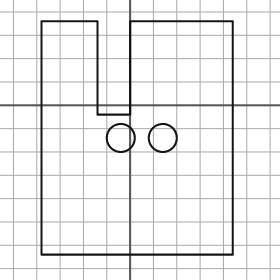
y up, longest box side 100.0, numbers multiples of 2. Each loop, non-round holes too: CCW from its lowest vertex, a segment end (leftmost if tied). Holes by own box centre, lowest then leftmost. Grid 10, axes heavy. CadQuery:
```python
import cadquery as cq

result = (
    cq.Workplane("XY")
    .moveTo(-38.0, -64.0)
    .lineTo(44.0, -64.0)
    .lineTo(44.0, 36.0)
    .lineTo(0.0, 36.0)
    .lineTo(0.0, -4.0)
    .lineTo(-14.0, -4.0)
    .lineTo(-14.0, 36.0)
    .lineTo(-38.0, 36.0)
    .close()
    .moveTo(-4.0, -14.0)
    .circle(6.0)
    .moveTo(14.0, -14.0)
    .circle(6.0)
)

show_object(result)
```